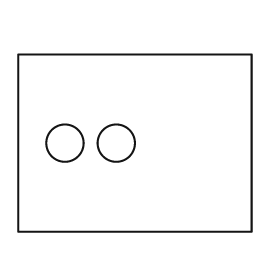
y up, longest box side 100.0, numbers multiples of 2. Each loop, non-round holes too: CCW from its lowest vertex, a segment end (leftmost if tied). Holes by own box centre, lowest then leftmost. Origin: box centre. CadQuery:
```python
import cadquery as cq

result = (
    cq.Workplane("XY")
    .moveTo(-50.0, -38.0)
    .lineTo(50.0, -38.0)
    .lineTo(50.0, 38.0)
    .lineTo(-50.0, 38.0)
    .close()
    .moveTo(-30.0, 0.0)
    .circle(8.0)
    .moveTo(-8.0, 0.0)
    .circle(8.0)
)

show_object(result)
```